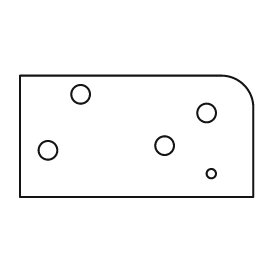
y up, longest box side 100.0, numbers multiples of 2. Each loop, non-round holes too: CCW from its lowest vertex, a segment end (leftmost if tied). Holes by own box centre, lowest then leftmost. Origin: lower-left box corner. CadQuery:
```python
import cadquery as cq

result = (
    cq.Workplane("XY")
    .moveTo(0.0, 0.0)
    .lineTo(100.0, 0.0)
    .lineTo(100.0, 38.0)
    .threePointArc((96.0, 48.0), (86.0, 52.0))
    .lineTo(0.0, 52.0)
    .close()
    .moveTo(82.0, 10.0)
    .circle(2.0)
    .moveTo(12.0, 20.0)
    .circle(4.0)
    .moveTo(62.0, 22.0)
    .circle(4.0)
    .moveTo(80.0, 36.0)
    .circle(4.0)
    .moveTo(26.0, 44.0)
    .circle(4.0)
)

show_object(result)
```